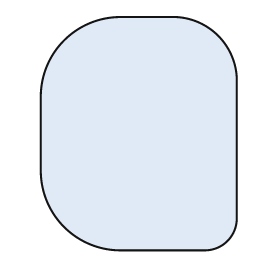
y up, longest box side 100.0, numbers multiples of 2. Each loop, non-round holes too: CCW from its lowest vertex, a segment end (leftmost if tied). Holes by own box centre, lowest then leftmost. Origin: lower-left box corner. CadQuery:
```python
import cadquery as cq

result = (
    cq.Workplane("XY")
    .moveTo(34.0, 0.0)
    .lineTo(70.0, 0.0)
    .threePointArc((80.0, 4.0), (84.0, 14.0))
    .lineTo(84.0, 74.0)
    .threePointArc((76.0, 92.0), (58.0, 100.0))
    .lineTo(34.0, 100.0)
    .threePointArc((10.0, 90.0), (0.0, 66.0))
    .lineTo(0.0, 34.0)
    .threePointArc((10.0, 10.0), (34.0, 0.0))
    .close()
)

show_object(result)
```